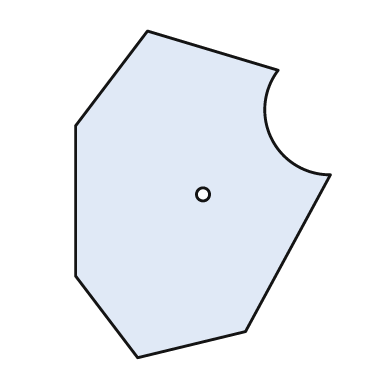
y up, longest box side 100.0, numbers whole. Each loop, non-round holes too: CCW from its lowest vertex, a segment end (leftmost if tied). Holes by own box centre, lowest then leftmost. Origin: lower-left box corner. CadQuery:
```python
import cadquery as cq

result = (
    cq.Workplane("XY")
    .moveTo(19.0, 0.0)
    .lineTo(52.0, 8.0)
    .lineTo(78.0, 56.0)
    .threePointArc((60.0, 67.0), (62.0, 88.0))
    .lineTo(22.0, 100.0)
    .lineTo(0.0, 71.0)
    .lineTo(0.0, 25.0)
    .close()
    .moveTo(39.0, 50.0)
    .circle(2.0)
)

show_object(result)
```